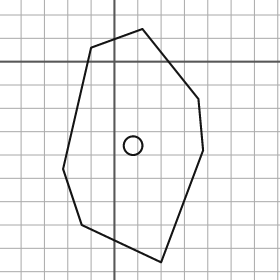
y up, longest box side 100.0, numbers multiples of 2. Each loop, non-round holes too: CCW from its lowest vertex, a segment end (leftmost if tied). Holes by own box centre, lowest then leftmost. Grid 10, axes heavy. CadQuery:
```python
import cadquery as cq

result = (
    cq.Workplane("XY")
    .moveTo(20.0, -86.0)
    .lineTo(38.0, -38.0)
    .lineTo(36.0, -16.0)
    .lineTo(12.0, 14.0)
    .lineTo(-10.0, 6.0)
    .lineTo(-22.0, -46.0)
    .lineTo(-14.0, -70.0)
    .close()
    .moveTo(8.0, -36.0)
    .circle(4.0)
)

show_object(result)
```